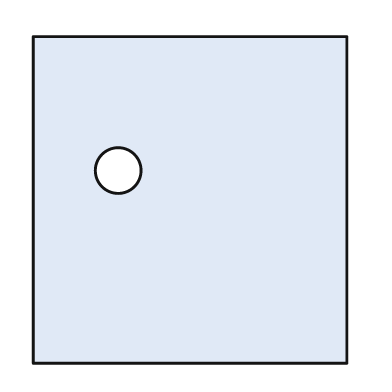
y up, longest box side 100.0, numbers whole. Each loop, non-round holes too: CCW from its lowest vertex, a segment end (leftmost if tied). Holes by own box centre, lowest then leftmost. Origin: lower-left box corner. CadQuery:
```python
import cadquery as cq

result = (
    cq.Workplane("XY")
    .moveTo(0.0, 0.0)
    .lineTo(96.0, 0.0)
    .lineTo(96.0, 100.0)
    .lineTo(0.0, 100.0)
    .close()
    .moveTo(26.0, 59.0)
    .circle(7.0)
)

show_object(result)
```